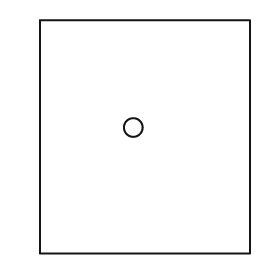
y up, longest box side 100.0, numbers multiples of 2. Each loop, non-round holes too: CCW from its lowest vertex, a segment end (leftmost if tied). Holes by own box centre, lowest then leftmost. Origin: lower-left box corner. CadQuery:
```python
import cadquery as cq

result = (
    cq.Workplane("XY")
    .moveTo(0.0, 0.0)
    .lineTo(90.0, 0.0)
    .lineTo(90.0, 100.0)
    .lineTo(0.0, 100.0)
    .close()
    .moveTo(40.0, 54.0)
    .circle(4.0)
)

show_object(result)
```